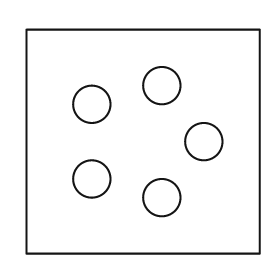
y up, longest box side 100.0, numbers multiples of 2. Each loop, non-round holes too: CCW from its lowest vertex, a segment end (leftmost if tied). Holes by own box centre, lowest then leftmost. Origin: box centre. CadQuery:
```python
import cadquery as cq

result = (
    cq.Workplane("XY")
    .moveTo(-50.0, -48.0)
    .lineTo(50.0, -48.0)
    .lineTo(50.0, 48.0)
    .lineTo(-50.0, 48.0)
    .close()
    .moveTo(8.0, -24.0)
    .circle(8.0)
    .moveTo(-22.0, -16.0)
    .circle(8.0)
    .moveTo(26.0, 0.0)
    .circle(8.0)
    .moveTo(-22.0, 16.0)
    .circle(8.0)
    .moveTo(8.0, 24.0)
    .circle(8.0)
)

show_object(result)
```